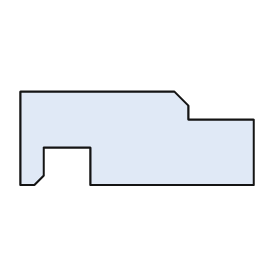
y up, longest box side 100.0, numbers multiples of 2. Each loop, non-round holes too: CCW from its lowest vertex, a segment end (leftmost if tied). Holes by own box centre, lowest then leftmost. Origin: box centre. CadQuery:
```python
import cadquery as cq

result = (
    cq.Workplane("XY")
    .moveTo(-50.0, -20.0)
    .lineTo(-44.0, -20.0)
    .lineTo(-40.0, -16.0)
    .lineTo(-40.0, -4.0)
    .lineTo(-20.0, -4.0)
    .lineTo(-20.0, -20.0)
    .lineTo(50.0, -20.0)
    .lineTo(50.0, 8.0)
    .lineTo(22.0, 8.0)
    .lineTo(22.0, 14.0)
    .lineTo(16.0, 20.0)
    .lineTo(-50.0, 20.0)
    .close()
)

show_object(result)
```